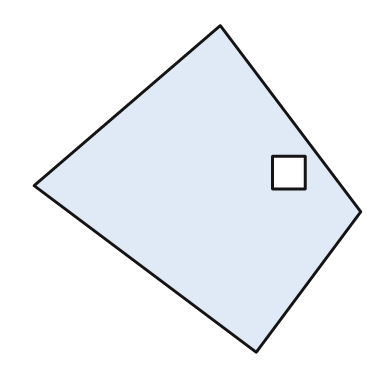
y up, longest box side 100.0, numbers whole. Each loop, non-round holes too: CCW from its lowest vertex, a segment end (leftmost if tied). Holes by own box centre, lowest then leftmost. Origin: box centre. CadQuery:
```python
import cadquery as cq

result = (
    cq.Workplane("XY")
    .moveTo(18.0, -50.0)
    .lineTo(50.0, -7.0)
    .lineTo(7.0, 50.0)
    .lineTo(-50.0, 1.0)
    .close()
    .moveTo(23.0, 0.0)
    .lineTo(33.0, 0.0)
    .lineTo(33.0, 10.0)
    .lineTo(23.0, 10.0)
    .close()
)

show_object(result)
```